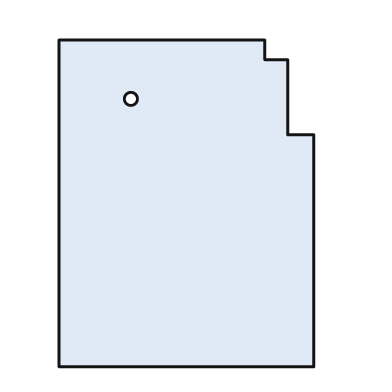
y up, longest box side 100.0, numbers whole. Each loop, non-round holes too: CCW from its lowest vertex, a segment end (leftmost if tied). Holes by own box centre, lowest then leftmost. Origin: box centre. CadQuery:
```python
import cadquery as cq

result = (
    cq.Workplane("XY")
    .moveTo(-39.0, -50.0)
    .lineTo(39.0, -50.0)
    .lineTo(39.0, 21.0)
    .lineTo(31.0, 21.0)
    .lineTo(31.0, 44.0)
    .lineTo(24.0, 44.0)
    .lineTo(24.0, 50.0)
    .lineTo(-39.0, 50.0)
    .close()
    .moveTo(-17.0, 32.0)
    .circle(2.0)
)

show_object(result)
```